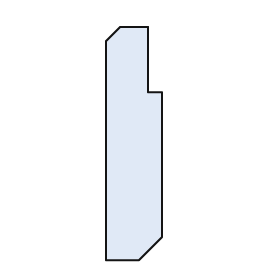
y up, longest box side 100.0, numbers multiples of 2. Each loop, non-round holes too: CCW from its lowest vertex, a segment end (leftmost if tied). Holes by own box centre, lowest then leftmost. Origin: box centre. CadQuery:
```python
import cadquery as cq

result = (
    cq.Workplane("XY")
    .moveTo(-12.0, -50.0)
    .lineTo(2.0, -50.0)
    .lineTo(12.0, -40.0)
    .lineTo(12.0, 22.0)
    .lineTo(6.0, 22.0)
    .lineTo(6.0, 50.0)
    .lineTo(-6.0, 50.0)
    .lineTo(-12.0, 44.0)
    .close()
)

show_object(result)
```